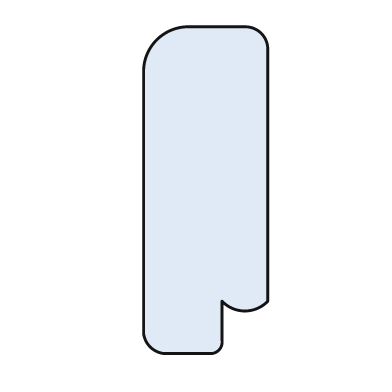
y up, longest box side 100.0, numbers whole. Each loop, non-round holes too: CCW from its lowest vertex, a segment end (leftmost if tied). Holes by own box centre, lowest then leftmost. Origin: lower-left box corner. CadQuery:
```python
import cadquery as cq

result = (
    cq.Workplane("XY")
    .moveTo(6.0, 0.0)
    .lineTo(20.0, 0.0)
    .threePointArc((23.0, 1.0), (24.0, 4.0))
    .lineTo(24.0, 16.0)
    .threePointArc((31.0, 13.0), (38.0, 16.0))
    .lineTo(38.0, 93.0)
    .threePointArc((36.0, 98.0), (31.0, 100.0))
    .lineTo(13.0, 100.0)
    .threePointArc((4.0, 96.0), (0.0, 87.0))
    .lineTo(0.0, 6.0)
    .threePointArc((2.0, 2.0), (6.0, 0.0))
    .close()
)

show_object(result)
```